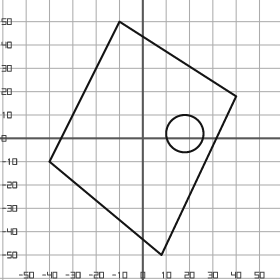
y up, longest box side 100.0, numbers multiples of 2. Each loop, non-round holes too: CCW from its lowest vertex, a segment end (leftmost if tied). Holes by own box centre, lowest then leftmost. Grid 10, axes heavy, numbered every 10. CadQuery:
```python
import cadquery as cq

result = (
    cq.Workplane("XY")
    .moveTo(8.0, -50.0)
    .lineTo(40.0, 18.0)
    .lineTo(-10.0, 50.0)
    .lineTo(-40.0, -10.0)
    .close()
    .moveTo(18.0, 2.0)
    .circle(8.0)
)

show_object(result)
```